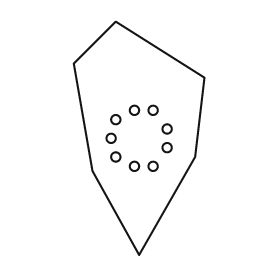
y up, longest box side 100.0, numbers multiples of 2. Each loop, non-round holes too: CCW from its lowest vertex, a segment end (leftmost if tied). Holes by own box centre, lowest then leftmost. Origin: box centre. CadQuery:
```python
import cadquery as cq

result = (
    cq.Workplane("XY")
    .moveTo(0.0, -50.0)
    .lineTo(24.0, -8.0)
    .lineTo(28.0, 26.0)
    .lineTo(-10.0, 50.0)
    .lineTo(-28.0, 32.0)
    .lineTo(-20.0, -14.0)
    .close()
    .moveTo(-2.0, -12.0)
    .circle(2.0)
    .moveTo(6.0, -12.0)
    .circle(2.0)
    .moveTo(-10.0, -8.0)
    .circle(2.0)
    .moveTo(12.0, -4.0)
    .circle(2.0)
    .moveTo(-12.0, 0.0)
    .circle(2.0)
    .moveTo(12.0, 4.0)
    .circle(2.0)
    .moveTo(-10.0, 8.0)
    .circle(2.0)
    .moveTo(-2.0, 12.0)
    .circle(2.0)
    .moveTo(6.0, 12.0)
    .circle(2.0)
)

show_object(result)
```